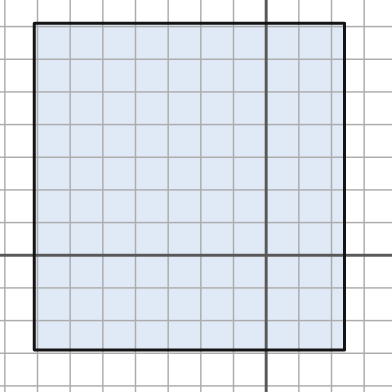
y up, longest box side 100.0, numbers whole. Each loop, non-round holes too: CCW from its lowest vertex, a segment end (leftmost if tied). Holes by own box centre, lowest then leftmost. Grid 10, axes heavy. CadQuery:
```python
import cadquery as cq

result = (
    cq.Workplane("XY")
    .moveTo(-71.0, -29.0)
    .lineTo(24.0, -29.0)
    .lineTo(24.0, 71.0)
    .lineTo(-71.0, 71.0)
    .close()
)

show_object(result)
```